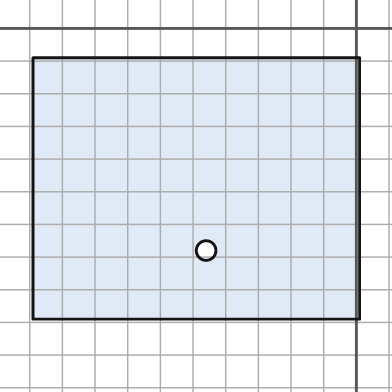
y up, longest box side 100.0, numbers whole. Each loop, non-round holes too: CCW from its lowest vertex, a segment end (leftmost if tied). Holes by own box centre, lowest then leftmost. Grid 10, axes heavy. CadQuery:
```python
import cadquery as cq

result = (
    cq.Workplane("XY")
    .moveTo(-99.0, -89.0)
    .lineTo(1.0, -89.0)
    .lineTo(1.0, -9.0)
    .lineTo(-99.0, -9.0)
    .close()
    .moveTo(-46.0, -68.0)
    .circle(3.0)
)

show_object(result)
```